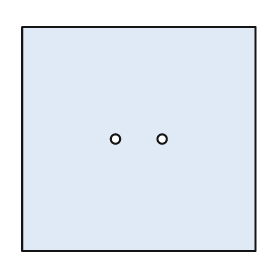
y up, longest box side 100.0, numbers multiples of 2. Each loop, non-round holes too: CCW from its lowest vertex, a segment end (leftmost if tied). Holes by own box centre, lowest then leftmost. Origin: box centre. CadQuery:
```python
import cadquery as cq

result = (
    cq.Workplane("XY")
    .moveTo(-50.0, -48.0)
    .lineTo(50.0, -48.0)
    .lineTo(50.0, 48.0)
    .lineTo(-50.0, 48.0)
    .close()
    .moveTo(-10.0, 0.0)
    .circle(2.0)
    .moveTo(10.0, 0.0)
    .circle(2.0)
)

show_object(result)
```